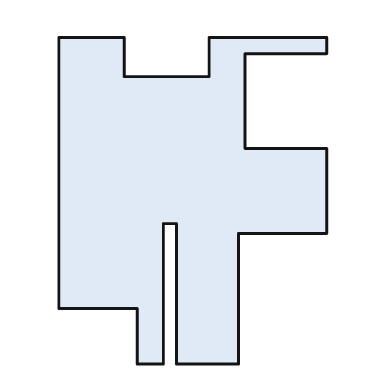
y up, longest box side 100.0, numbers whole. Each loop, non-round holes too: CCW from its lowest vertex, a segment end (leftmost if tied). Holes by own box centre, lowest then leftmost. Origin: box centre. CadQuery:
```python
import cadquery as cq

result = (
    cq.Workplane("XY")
    .moveTo(-17.0, -50.0)
    .lineTo(-9.0, -50.0)
    .lineTo(-9.0, -7.0)
    .lineTo(-5.0, -7.0)
    .lineTo(-5.0, -50.0)
    .lineTo(14.0, -50.0)
    .lineTo(14.0, -10.0)
    .lineTo(41.0, -10.0)
    .lineTo(41.0, 16.0)
    .lineTo(16.0, 16.0)
    .lineTo(16.0, 45.0)
    .lineTo(41.0, 45.0)
    .lineTo(41.0, 50.0)
    .lineTo(5.0, 50.0)
    .lineTo(5.0, 38.0)
    .lineTo(-21.0, 38.0)
    .lineTo(-21.0, 50.0)
    .lineTo(-41.0, 50.0)
    .lineTo(-41.0, -33.0)
    .lineTo(-17.0, -33.0)
    .close()
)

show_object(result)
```